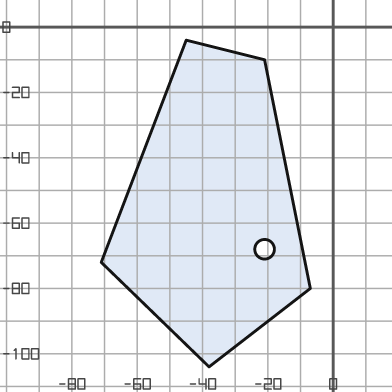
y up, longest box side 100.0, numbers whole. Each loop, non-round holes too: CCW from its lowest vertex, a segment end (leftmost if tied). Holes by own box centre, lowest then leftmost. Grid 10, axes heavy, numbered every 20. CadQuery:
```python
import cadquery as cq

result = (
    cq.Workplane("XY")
    .moveTo(-38.0, -104.0)
    .lineTo(-7.0, -80.0)
    .lineTo(-21.0, -10.0)
    .lineTo(-45.0, -4.0)
    .lineTo(-71.0, -72.0)
    .close()
    .moveTo(-21.0, -68.0)
    .circle(3.0)
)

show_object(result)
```